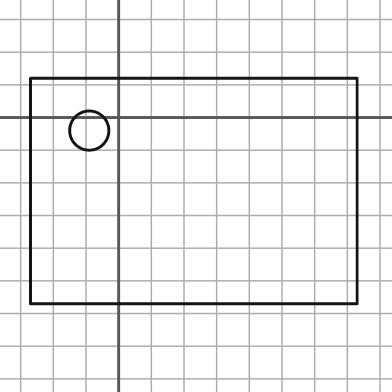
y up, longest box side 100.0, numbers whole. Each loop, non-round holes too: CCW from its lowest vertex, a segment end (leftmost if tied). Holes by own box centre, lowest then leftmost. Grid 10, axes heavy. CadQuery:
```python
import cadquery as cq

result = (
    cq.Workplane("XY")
    .moveTo(-27.0, -57.0)
    .lineTo(73.0, -57.0)
    .lineTo(73.0, 12.0)
    .lineTo(-27.0, 12.0)
    .close()
    .moveTo(-9.0, -4.0)
    .circle(6.0)
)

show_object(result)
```